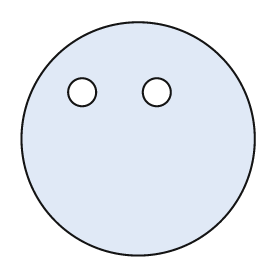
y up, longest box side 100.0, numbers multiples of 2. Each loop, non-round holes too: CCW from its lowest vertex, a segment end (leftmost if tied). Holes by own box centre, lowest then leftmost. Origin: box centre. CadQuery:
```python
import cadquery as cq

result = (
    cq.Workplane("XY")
    .moveTo(0.0, 0.0)
    .circle(50.0)
    .moveTo(-24.0, 20.0)
    .circle(6.0)
    .moveTo(8.0, 20.0)
    .circle(6.0)
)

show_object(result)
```